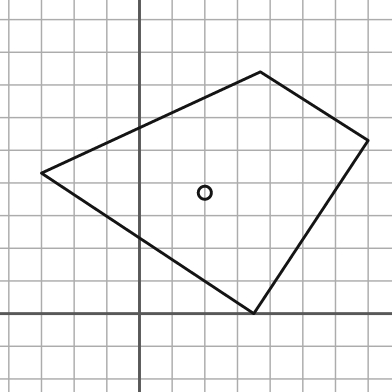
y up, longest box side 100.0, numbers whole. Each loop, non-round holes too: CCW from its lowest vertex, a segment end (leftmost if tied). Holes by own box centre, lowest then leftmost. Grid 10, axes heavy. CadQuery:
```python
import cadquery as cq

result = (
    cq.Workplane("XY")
    .moveTo(35.0, 0.0)
    .lineTo(70.0, 53.0)
    .lineTo(37.0, 74.0)
    .lineTo(-30.0, 43.0)
    .close()
    .moveTo(20.0, 37.0)
    .circle(2.0)
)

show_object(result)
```